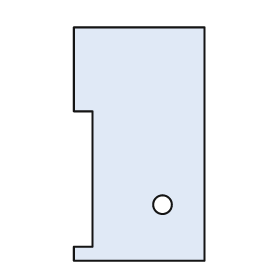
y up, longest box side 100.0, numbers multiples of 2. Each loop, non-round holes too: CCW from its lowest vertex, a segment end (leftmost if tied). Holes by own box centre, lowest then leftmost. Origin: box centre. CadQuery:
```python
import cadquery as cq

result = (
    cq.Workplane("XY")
    .moveTo(-28.0, -50.0)
    .lineTo(28.0, -50.0)
    .lineTo(28.0, 50.0)
    .lineTo(-28.0, 50.0)
    .lineTo(-28.0, 14.0)
    .lineTo(-20.0, 14.0)
    .lineTo(-20.0, -44.0)
    .lineTo(-28.0, -44.0)
    .close()
    .moveTo(10.0, -26.0)
    .circle(4.0)
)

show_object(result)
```